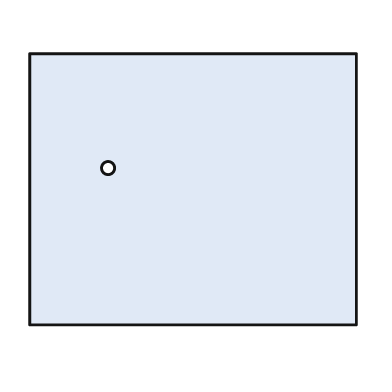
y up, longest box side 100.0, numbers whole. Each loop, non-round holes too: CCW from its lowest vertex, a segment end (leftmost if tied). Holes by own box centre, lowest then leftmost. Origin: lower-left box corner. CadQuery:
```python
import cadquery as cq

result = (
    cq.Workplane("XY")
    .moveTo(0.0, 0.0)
    .lineTo(100.0, 0.0)
    .lineTo(100.0, 83.0)
    .lineTo(0.0, 83.0)
    .close()
    .moveTo(24.0, 48.0)
    .circle(2.0)
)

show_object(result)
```